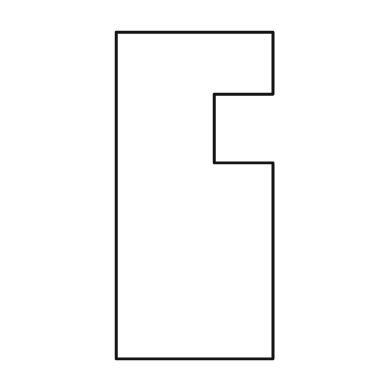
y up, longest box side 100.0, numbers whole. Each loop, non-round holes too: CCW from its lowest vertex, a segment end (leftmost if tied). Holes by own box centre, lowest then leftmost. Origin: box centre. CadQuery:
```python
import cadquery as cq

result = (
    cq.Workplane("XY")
    .moveTo(-24.0, -50.0)
    .lineTo(24.0, -50.0)
    .lineTo(24.0, 10.0)
    .lineTo(6.0, 10.0)
    .lineTo(6.0, 31.0)
    .lineTo(24.0, 31.0)
    .lineTo(24.0, 50.0)
    .lineTo(-24.0, 50.0)
    .close()
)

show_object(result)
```